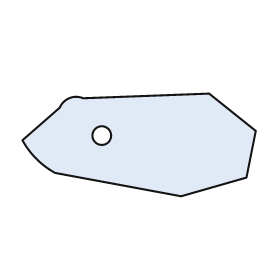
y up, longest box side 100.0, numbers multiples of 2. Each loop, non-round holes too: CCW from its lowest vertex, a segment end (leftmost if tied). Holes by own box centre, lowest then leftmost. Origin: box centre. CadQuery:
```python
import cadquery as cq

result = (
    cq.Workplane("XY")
    .moveTo(18.0, -22.0)
    .lineTo(46.0, -14.0)
    .lineTo(50.0, 6.0)
    .lineTo(30.0, 22.0)
    .lineTo(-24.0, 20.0)
    .threePointArc((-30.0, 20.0), (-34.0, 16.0))
    .lineTo(-50.0, 2.0)
    .threePointArc((-44.0, -6.0), (-36.0, -12.0))
    .close()
    .moveTo(-16.0, 4.0)
    .circle(4.0)
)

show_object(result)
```